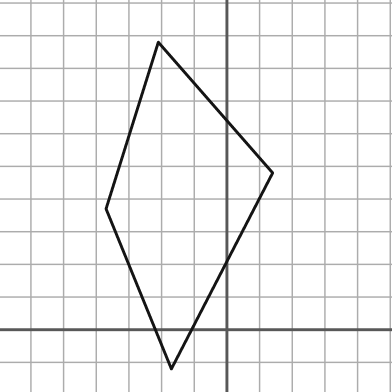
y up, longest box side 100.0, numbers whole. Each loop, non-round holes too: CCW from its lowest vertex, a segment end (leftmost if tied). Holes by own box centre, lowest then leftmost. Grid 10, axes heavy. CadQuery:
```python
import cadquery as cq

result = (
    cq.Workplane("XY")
    .moveTo(-17.0, -12.0)
    .lineTo(14.0, 48.0)
    .lineTo(-21.0, 88.0)
    .lineTo(-37.0, 37.0)
    .close()
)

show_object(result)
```